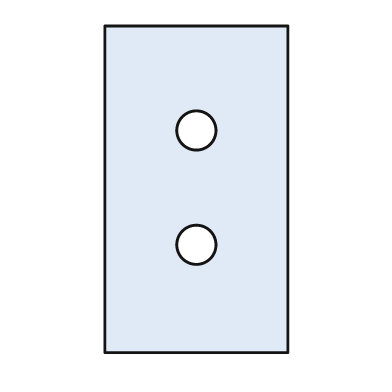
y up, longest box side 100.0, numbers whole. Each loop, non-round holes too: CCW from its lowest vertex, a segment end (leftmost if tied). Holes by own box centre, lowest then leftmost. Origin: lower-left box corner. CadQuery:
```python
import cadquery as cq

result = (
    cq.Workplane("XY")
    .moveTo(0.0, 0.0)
    .lineTo(56.0, 0.0)
    .lineTo(56.0, 100.0)
    .lineTo(0.0, 100.0)
    .close()
    .moveTo(28.0, 33.0)
    .circle(6.0)
    .moveTo(28.0, 68.0)
    .circle(6.0)
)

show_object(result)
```